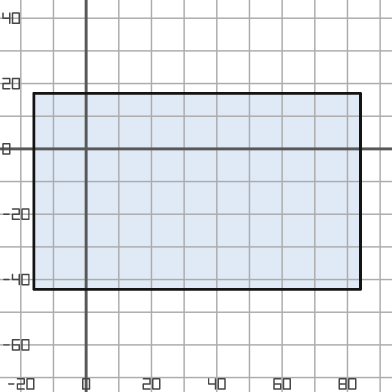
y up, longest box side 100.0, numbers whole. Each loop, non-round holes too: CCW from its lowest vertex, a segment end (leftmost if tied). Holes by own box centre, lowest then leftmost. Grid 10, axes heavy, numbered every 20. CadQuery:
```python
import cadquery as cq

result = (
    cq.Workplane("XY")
    .moveTo(-16.0, -43.0)
    .lineTo(84.0, -43.0)
    .lineTo(84.0, 17.0)
    .lineTo(-16.0, 17.0)
    .close()
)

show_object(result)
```